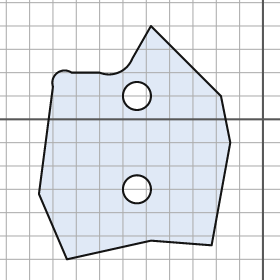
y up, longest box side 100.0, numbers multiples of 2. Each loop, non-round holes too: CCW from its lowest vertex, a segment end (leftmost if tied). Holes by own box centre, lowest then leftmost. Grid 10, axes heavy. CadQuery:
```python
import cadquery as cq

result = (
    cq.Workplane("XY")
    .moveTo(-84.0, -60.0)
    .lineTo(-48.0, -52.0)
    .lineTo(-22.0, -54.0)
    .lineTo(-14.0, -10.0)
    .lineTo(-18.0, 10.0)
    .lineTo(-48.0, 40.0)
    .lineTo(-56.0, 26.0)
    .threePointArc((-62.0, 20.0), (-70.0, 20.0))
    .lineTo(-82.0, 20.0)
    .threePointArc((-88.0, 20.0), (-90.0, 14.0))
    .lineTo(-96.0, -32.0)
    .close()
    .moveTo(-54.0, -30.0)
    .circle(6.0)
    .moveTo(-54.0, 10.0)
    .circle(6.0)
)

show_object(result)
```